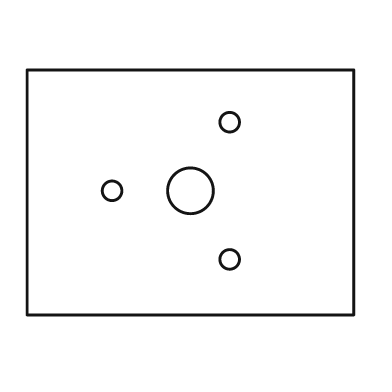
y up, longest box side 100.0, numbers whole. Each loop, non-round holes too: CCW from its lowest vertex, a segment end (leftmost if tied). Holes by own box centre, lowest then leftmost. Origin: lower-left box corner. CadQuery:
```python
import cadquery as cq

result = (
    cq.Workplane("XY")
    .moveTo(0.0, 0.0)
    .lineTo(100.0, 0.0)
    .lineTo(100.0, 75.0)
    .lineTo(0.0, 75.0)
    .close()
    .moveTo(62.0, 17.0)
    .circle(3.0)
    .moveTo(26.0, 38.0)
    .circle(3.0)
    .moveTo(50.0, 38.0)
    .circle(7.0)
    .moveTo(62.0, 59.0)
    .circle(3.0)
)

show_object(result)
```